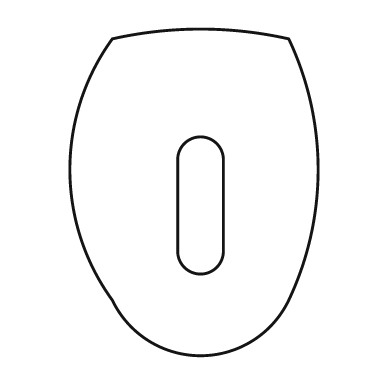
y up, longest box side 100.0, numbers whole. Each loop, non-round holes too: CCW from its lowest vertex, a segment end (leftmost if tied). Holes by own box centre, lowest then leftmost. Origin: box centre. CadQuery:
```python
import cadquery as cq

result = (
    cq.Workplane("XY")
    .moveTo(-25.0, -33.0)
    .threePointArc((2.0, -50.0), (29.0, -33.0))
    .threePointArc((38.0, 7.0), (29.0, 47.0))
    .threePointArc((2.0, 50.0), (-25.0, 47.0))
    .threePointArc((-38.0, 7.0), (-25.0, -33.0))
    .close()
    .moveTo(-5.0, -18.0)
    .threePointArc((2.0, -25.0), (9.0, -18.0))
    .lineTo(9.0, 10.0)
    .threePointArc((2.0, 17.0), (-5.0, 10.0))
    .close()
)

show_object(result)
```